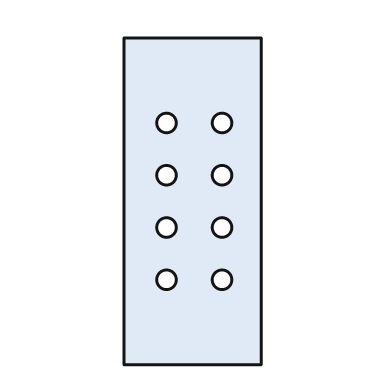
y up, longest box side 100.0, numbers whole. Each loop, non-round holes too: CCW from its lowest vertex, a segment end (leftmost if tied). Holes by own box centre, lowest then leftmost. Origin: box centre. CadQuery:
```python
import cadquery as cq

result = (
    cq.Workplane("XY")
    .moveTo(-21.0, -50.0)
    .lineTo(21.0, -50.0)
    .lineTo(21.0, 50.0)
    .lineTo(-21.0, 50.0)
    .close()
    .moveTo(-8.0, -24.0)
    .circle(3.0)
    .moveTo(9.0, -24.0)
    .circle(3.0)
    .moveTo(-8.0, -8.0)
    .circle(3.0)
    .moveTo(9.0, -8.0)
    .circle(3.0)
    .moveTo(-8.0, 8.0)
    .circle(3.0)
    .moveTo(9.0, 8.0)
    .circle(3.0)
    .moveTo(-8.0, 24.0)
    .circle(3.0)
    .moveTo(9.0, 24.0)
    .circle(3.0)
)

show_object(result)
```